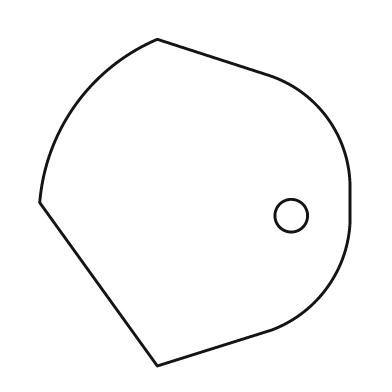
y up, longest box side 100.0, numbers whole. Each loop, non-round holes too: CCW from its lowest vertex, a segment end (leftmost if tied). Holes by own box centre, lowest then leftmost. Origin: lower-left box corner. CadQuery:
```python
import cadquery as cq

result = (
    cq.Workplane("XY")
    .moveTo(36.0, 0.0)
    .lineTo(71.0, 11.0)
    .threePointArc((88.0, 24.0), (95.0, 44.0))
    .lineTo(95.0, 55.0)
    .threePointArc((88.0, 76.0), (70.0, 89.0))
    .lineTo(36.0, 100.0)
    .threePointArc((11.0, 80.0), (0.0, 50.0))
    .close()
    .moveTo(77.0, 46.0)
    .circle(5.0)
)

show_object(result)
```